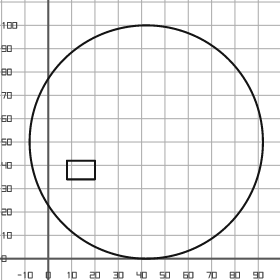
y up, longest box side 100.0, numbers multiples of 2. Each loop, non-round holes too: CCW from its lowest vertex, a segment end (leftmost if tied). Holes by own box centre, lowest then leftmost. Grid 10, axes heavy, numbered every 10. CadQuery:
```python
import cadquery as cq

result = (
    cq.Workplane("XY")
    .moveTo(42.0, 50.0)
    .circle(50.0)
    .moveTo(8.0, 34.0)
    .lineTo(20.0, 34.0)
    .lineTo(20.0, 42.0)
    .lineTo(8.0, 42.0)
    .close()
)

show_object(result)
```